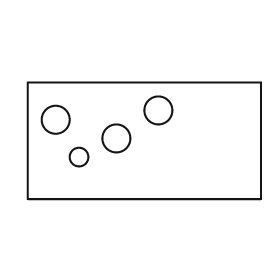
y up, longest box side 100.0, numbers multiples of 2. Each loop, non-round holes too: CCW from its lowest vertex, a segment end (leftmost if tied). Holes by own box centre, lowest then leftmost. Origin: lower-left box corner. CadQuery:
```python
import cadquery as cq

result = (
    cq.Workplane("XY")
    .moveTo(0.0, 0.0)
    .lineTo(100.0, 0.0)
    .lineTo(100.0, 50.0)
    .lineTo(0.0, 50.0)
    .close()
    .moveTo(22.0, 18.0)
    .circle(4.0)
    .moveTo(38.0, 26.0)
    .circle(6.0)
    .moveTo(12.0, 34.0)
    .circle(6.0)
    .moveTo(56.0, 38.0)
    .circle(6.0)
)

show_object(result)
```